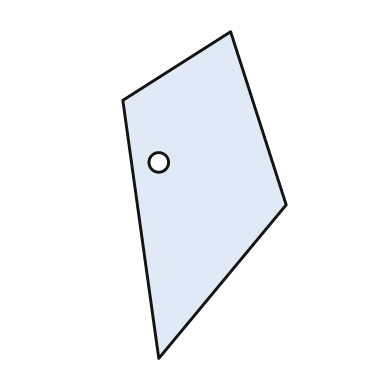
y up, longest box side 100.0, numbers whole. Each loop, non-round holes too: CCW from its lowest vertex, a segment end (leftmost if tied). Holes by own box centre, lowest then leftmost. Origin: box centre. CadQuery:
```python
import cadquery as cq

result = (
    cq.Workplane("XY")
    .moveTo(-14.0, -50.0)
    .lineTo(25.0, -3.0)
    .lineTo(8.0, 50.0)
    .lineTo(-25.0, 29.0)
    .close()
    .moveTo(-14.0, 10.0)
    .circle(3.0)
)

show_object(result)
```